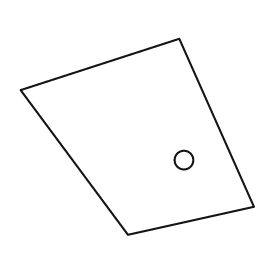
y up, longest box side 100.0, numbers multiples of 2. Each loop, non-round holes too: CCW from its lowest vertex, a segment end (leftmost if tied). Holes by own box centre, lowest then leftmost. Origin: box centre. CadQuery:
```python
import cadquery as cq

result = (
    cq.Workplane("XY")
    .moveTo(-4.0, -42.0)
    .lineTo(50.0, -30.0)
    .lineTo(18.0, 42.0)
    .lineTo(-50.0, 20.0)
    .close()
    .moveTo(20.0, -10.0)
    .circle(4.0)
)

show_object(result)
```